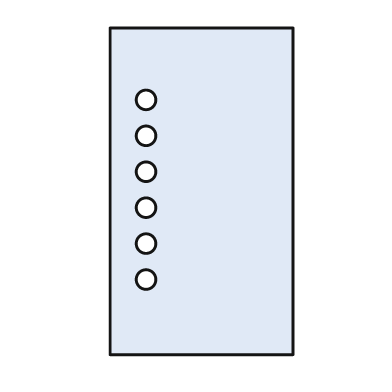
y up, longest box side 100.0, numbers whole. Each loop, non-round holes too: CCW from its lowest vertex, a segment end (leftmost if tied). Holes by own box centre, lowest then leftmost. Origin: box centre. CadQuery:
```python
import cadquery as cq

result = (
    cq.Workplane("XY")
    .moveTo(-28.0, -50.0)
    .lineTo(28.0, -50.0)
    .lineTo(28.0, 50.0)
    .lineTo(-28.0, 50.0)
    .close()
    .moveTo(-17.0, -27.0)
    .circle(3.0)
    .moveTo(-17.0, -16.0)
    .circle(3.0)
    .moveTo(-17.0, -5.0)
    .circle(3.0)
    .moveTo(-17.0, 6.0)
    .circle(3.0)
    .moveTo(-17.0, 17.0)
    .circle(3.0)
    .moveTo(-17.0, 28.0)
    .circle(3.0)
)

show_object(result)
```